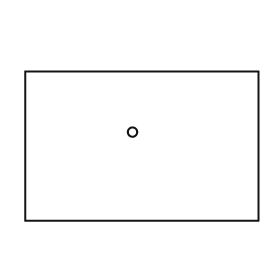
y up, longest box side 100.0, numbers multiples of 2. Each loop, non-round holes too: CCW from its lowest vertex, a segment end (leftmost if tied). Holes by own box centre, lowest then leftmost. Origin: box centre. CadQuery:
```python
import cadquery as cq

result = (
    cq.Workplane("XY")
    .moveTo(-50.0, -32.0)
    .lineTo(50.0, -32.0)
    .lineTo(50.0, 32.0)
    .lineTo(-50.0, 32.0)
    .close()
    .moveTo(-4.0, 6.0)
    .circle(2.0)
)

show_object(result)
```